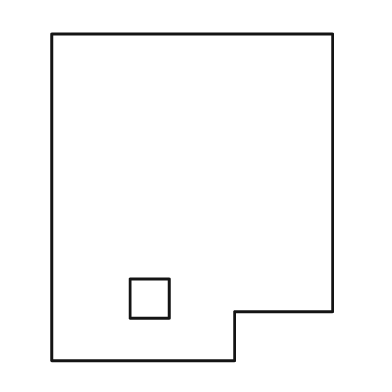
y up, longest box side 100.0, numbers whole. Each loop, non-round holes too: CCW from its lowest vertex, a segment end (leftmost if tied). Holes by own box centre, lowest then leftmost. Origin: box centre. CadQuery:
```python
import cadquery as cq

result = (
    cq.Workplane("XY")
    .moveTo(-43.0, -50.0)
    .lineTo(13.0, -50.0)
    .lineTo(13.0, -35.0)
    .lineTo(43.0, -35.0)
    .lineTo(43.0, 50.0)
    .lineTo(-43.0, 50.0)
    .close()
    .moveTo(-19.0, -37.0)
    .lineTo(-7.0, -37.0)
    .lineTo(-7.0, -25.0)
    .lineTo(-19.0, -25.0)
    .close()
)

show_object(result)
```